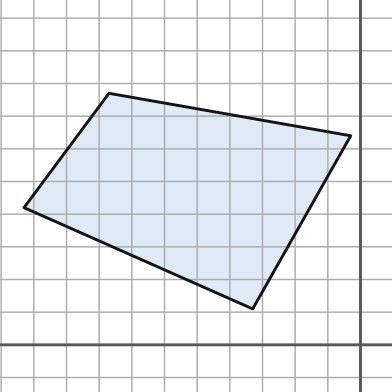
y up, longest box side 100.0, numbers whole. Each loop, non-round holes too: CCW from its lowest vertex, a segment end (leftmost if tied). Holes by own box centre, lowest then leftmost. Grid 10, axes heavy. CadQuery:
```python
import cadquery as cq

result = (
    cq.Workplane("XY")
    .moveTo(-33.0, 11.0)
    .lineTo(-3.0, 64.0)
    .lineTo(-77.0, 77.0)
    .lineTo(-103.0, 42.0)
    .close()
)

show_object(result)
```